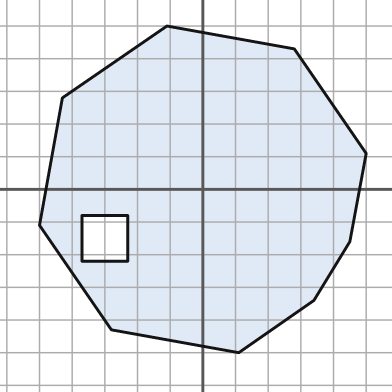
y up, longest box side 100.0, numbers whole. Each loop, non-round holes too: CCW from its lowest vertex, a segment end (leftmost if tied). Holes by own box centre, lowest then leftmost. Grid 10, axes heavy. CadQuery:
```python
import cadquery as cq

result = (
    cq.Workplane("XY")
    .moveTo(11.0, -50.0)
    .lineTo(34.0, -34.0)
    .lineTo(45.0, -16.0)
    .lineTo(50.0, 11.0)
    .lineTo(28.0, 43.0)
    .lineTo(-11.0, 50.0)
    .lineTo(-43.0, 28.0)
    .lineTo(-50.0, -11.0)
    .lineTo(-28.0, -43.0)
    .close()
    .moveTo(-37.0, -22.0)
    .lineTo(-23.0, -22.0)
    .lineTo(-23.0, -8.0)
    .lineTo(-37.0, -8.0)
    .close()
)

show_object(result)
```